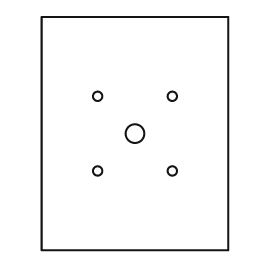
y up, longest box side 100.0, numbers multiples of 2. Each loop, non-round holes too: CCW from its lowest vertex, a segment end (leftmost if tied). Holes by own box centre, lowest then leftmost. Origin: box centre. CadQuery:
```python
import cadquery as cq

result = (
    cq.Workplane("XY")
    .moveTo(-40.0, -50.0)
    .lineTo(40.0, -50.0)
    .lineTo(40.0, 50.0)
    .lineTo(-40.0, 50.0)
    .close()
    .moveTo(-16.0, -16.0)
    .circle(2.0)
    .moveTo(16.0, -16.0)
    .circle(2.0)
    .moveTo(0.0, 0.0)
    .circle(4.0)
    .moveTo(-16.0, 16.0)
    .circle(2.0)
    .moveTo(16.0, 16.0)
    .circle(2.0)
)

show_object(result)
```